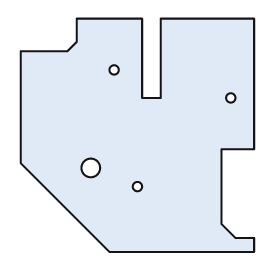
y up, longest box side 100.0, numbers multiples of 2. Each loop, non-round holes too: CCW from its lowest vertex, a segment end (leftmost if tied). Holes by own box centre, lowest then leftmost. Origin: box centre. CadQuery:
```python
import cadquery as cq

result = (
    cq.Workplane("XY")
    .moveTo(-12.0, -50.0)
    .lineTo(50.0, -50.0)
    .lineTo(50.0, -44.0)
    .lineTo(42.0, -44.0)
    .lineTo(36.0, -38.0)
    .lineTo(36.0, -6.0)
    .lineTo(50.0, -6.0)
    .lineTo(50.0, 50.0)
    .lineTo(10.0, 50.0)
    .lineTo(10.0, 16.0)
    .lineTo(2.0, 16.0)
    .lineTo(2.0, 50.0)
    .lineTo(-26.0, 50.0)
    .lineTo(-26.0, 40.0)
    .lineTo(-30.0, 36.0)
    .lineTo(-50.0, 36.0)
    .lineTo(-50.0, -12.0)
    .close()
    .moveTo(0.0, -22.0)
    .circle(2.0)
    .moveTo(-20.0, -14.0)
    .circle(4.0)
    .moveTo(40.0, 16.0)
    .circle(2.0)
    .moveTo(-10.0, 28.0)
    .circle(2.0)
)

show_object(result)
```